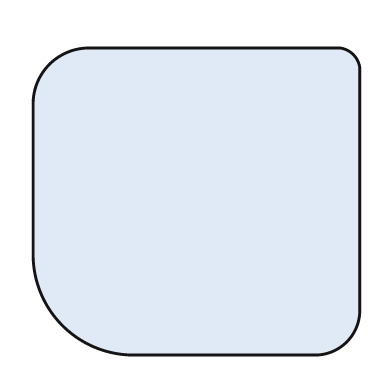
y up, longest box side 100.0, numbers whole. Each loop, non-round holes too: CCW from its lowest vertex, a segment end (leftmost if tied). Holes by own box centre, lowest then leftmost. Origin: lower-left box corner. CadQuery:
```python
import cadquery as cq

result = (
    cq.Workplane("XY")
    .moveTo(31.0, 0.0)
    .lineTo(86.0, 0.0)
    .threePointArc((96.0, 4.0), (100.0, 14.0))
    .lineTo(100.0, 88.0)
    .threePointArc((98.0, 92.0), (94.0, 94.0))
    .lineTo(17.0, 94.0)
    .threePointArc((5.0, 89.0), (0.0, 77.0))
    .lineTo(0.0, 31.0)
    .threePointArc((9.0, 9.0), (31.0, 0.0))
    .close()
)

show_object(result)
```